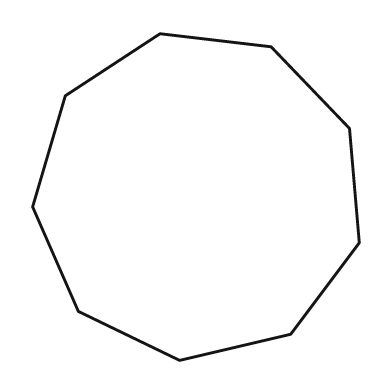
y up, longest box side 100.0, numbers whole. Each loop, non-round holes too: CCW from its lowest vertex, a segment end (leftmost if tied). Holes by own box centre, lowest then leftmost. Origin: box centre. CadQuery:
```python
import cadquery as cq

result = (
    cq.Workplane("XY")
    .moveTo(-5.0, -50.0)
    .lineTo(29.0, -42.0)
    .lineTo(50.0, -14.0)
    .lineTo(47.0, 21.0)
    .lineTo(23.0, 46.0)
    .lineTo(-11.0, 50.0)
    .lineTo(-40.0, 31.0)
    .lineTo(-50.0, -3.0)
    .lineTo(-36.0, -35.0)
    .close()
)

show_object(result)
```